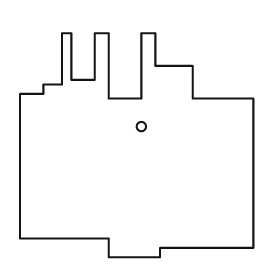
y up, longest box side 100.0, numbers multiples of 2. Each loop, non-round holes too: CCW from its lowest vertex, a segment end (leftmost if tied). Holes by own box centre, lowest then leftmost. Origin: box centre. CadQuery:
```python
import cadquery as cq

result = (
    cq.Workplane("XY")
    .moveTo(-12.0, -48.0)
    .lineTo(10.0, -48.0)
    .lineTo(10.0, -44.0)
    .lineTo(50.0, -44.0)
    .lineTo(50.0, 20.0)
    .lineTo(24.0, 20.0)
    .lineTo(24.0, 34.0)
    .lineTo(8.0, 34.0)
    .lineTo(8.0, 48.0)
    .lineTo(2.0, 48.0)
    .lineTo(2.0, 20.0)
    .lineTo(-12.0, 20.0)
    .lineTo(-12.0, 48.0)
    .lineTo(-18.0, 48.0)
    .lineTo(-18.0, 28.0)
    .lineTo(-28.0, 28.0)
    .lineTo(-28.0, 48.0)
    .lineTo(-32.0, 48.0)
    .lineTo(-32.0, 26.0)
    .lineTo(-40.0, 26.0)
    .lineTo(-40.0, 22.0)
    .lineTo(-50.0, 22.0)
    .lineTo(-50.0, -40.0)
    .lineTo(-12.0, -40.0)
    .close()
    .moveTo(2.0, 8.0)
    .circle(2.0)
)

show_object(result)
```